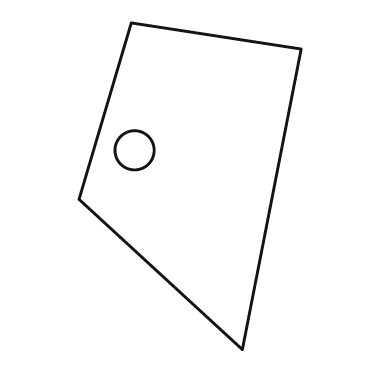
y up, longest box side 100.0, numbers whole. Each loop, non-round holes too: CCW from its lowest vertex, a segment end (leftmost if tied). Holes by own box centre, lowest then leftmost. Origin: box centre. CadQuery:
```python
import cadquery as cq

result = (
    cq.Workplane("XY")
    .moveTo(16.0, -50.0)
    .lineTo(34.0, 42.0)
    .lineTo(-18.0, 50.0)
    .lineTo(-34.0, -4.0)
    .close()
    .moveTo(-17.0, 11.0)
    .circle(6.0)
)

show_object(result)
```